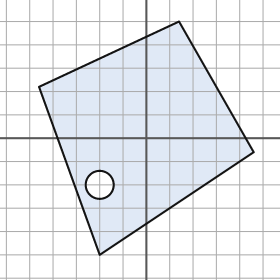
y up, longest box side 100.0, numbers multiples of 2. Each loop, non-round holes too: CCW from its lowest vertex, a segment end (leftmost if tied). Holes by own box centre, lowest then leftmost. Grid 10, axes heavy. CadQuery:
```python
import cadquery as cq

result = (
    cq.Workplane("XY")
    .moveTo(-20.0, -50.0)
    .lineTo(46.0, -6.0)
    .lineTo(14.0, 50.0)
    .lineTo(-46.0, 22.0)
    .close()
    .moveTo(-20.0, -20.0)
    .circle(6.0)
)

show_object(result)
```